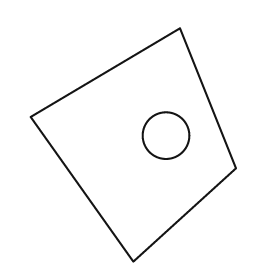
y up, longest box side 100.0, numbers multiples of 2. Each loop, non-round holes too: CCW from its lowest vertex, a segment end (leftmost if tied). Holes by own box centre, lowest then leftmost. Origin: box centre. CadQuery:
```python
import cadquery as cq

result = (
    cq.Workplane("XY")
    .moveTo(0.0, -50.0)
    .lineTo(44.0, -10.0)
    .lineTo(20.0, 50.0)
    .lineTo(-44.0, 12.0)
    .close()
    .moveTo(14.0, 4.0)
    .circle(10.0)
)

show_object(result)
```